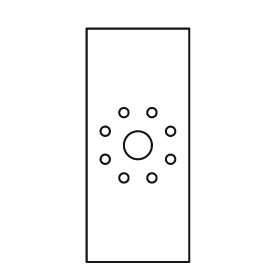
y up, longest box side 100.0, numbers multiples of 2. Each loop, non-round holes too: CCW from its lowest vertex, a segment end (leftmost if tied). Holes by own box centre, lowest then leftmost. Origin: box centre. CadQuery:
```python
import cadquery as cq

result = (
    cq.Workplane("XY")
    .moveTo(-22.0, -50.0)
    .lineTo(22.0, -50.0)
    .lineTo(22.0, 50.0)
    .lineTo(-22.0, 50.0)
    .close()
    .moveTo(-6.0, -14.0)
    .circle(2.0)
    .moveTo(6.0, -14.0)
    .circle(2.0)
    .moveTo(-14.0, -6.0)
    .circle(2.0)
    .moveTo(14.0, -6.0)
    .circle(2.0)
    .moveTo(0.0, 0.0)
    .circle(6.0)
    .moveTo(-14.0, 6.0)
    .circle(2.0)
    .moveTo(14.0, 6.0)
    .circle(2.0)
    .moveTo(-6.0, 14.0)
    .circle(2.0)
    .moveTo(6.0, 14.0)
    .circle(2.0)
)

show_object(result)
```